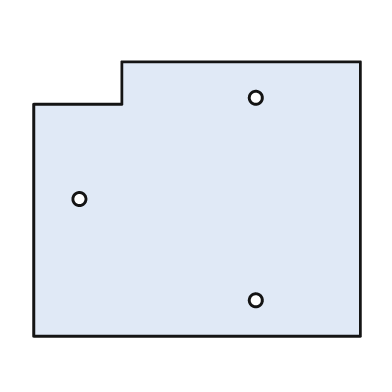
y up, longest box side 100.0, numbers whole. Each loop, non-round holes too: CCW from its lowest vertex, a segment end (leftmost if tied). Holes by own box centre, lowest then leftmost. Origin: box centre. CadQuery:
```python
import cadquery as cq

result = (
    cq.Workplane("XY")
    .moveTo(-50.0, -42.0)
    .lineTo(50.0, -42.0)
    .lineTo(50.0, 42.0)
    .lineTo(-23.0, 42.0)
    .lineTo(-23.0, 29.0)
    .lineTo(-50.0, 29.0)
    .close()
    .moveTo(18.0, -31.0)
    .circle(2.0)
    .moveTo(-36.0, 0.0)
    .circle(2.0)
    .moveTo(18.0, 31.0)
    .circle(2.0)
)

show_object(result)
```